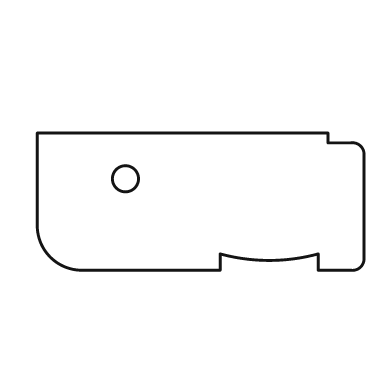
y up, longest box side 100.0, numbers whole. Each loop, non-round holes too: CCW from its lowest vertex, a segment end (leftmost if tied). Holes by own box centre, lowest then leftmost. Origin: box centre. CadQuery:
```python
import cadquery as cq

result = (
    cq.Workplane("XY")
    .moveTo(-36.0, -21.0)
    .lineTo(6.0, -21.0)
    .lineTo(6.0, -16.0)
    .threePointArc((21.0, -18.0), (36.0, -16.0))
    .lineTo(36.0, -21.0)
    .lineTo(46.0, -21.0)
    .threePointArc((49.0, -20.0), (50.0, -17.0))
    .lineTo(50.0, 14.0)
    .threePointArc((49.0, 17.0), (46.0, 18.0))
    .lineTo(39.0, 18.0)
    .lineTo(39.0, 21.0)
    .lineTo(-50.0, 21.0)
    .lineTo(-50.0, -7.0)
    .threePointArc((-46.0, -17.0), (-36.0, -21.0))
    .close()
    .moveTo(-23.0, 7.0)
    .circle(4.0)
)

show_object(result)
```